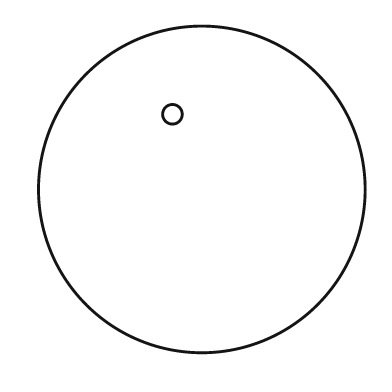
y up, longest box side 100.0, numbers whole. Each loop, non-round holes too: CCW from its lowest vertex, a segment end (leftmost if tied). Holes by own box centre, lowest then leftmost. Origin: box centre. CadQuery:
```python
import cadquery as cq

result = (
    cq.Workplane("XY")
    .moveTo(0.0, 0.0)
    .circle(50.0)
    .moveTo(-9.0, 23.0)
    .circle(3.0)
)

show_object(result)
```